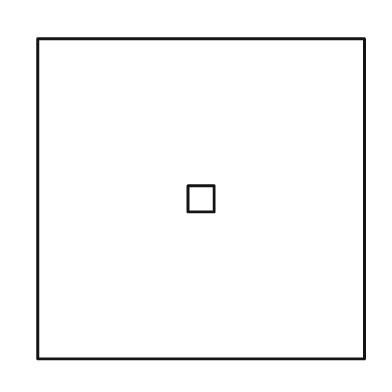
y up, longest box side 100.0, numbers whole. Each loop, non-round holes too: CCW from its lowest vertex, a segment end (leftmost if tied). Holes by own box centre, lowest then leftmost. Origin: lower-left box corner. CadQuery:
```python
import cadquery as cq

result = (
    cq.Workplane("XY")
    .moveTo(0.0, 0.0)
    .lineTo(100.0, 0.0)
    .lineTo(100.0, 98.0)
    .lineTo(0.0, 98.0)
    .close()
    .moveTo(46.0, 45.0)
    .lineTo(54.0, 45.0)
    .lineTo(54.0, 53.0)
    .lineTo(46.0, 53.0)
    .close()
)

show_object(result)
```